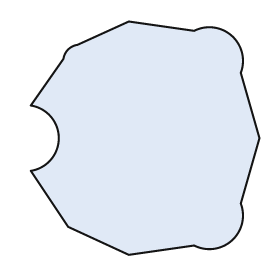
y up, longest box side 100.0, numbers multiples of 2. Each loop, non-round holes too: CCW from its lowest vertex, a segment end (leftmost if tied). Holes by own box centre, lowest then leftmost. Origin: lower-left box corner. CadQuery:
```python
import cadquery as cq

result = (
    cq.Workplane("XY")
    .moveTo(42.0, 0.0)
    .lineTo(70.0, 4.0)
    .threePointArc((86.0, 6.0), (90.0, 22.0))
    .lineTo(98.0, 50.0)
    .lineTo(90.0, 78.0)
    .threePointArc((86.0, 94.0), (70.0, 96.0))
    .lineTo(42.0, 100.0)
    .lineTo(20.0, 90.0)
    .threePointArc((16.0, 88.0), (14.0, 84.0))
    .lineTo(0.0, 64.0)
    .threePointArc((12.0, 50.0), (0.0, 36.0))
    .lineTo(16.0, 12.0)
    .close()
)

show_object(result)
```